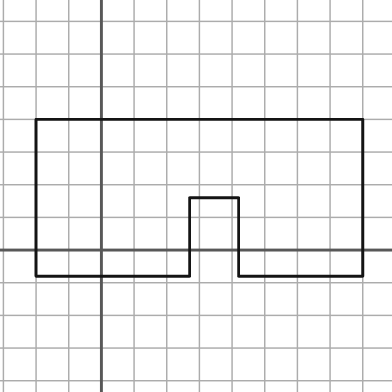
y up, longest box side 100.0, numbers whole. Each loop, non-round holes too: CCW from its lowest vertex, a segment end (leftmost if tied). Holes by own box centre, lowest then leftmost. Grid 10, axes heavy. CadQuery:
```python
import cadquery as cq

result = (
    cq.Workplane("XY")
    .moveTo(-20.0, -8.0)
    .lineTo(27.0, -8.0)
    .lineTo(27.0, 16.0)
    .lineTo(42.0, 16.0)
    .lineTo(42.0, -8.0)
    .lineTo(80.0, -8.0)
    .lineTo(80.0, 40.0)
    .lineTo(-20.0, 40.0)
    .close()
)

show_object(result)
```